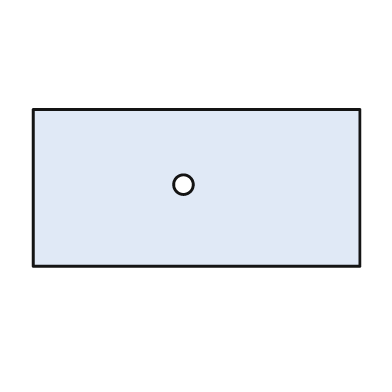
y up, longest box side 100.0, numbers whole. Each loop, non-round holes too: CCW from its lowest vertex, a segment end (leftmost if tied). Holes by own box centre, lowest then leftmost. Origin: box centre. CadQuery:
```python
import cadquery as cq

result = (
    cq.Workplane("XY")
    .moveTo(-50.0, -24.0)
    .lineTo(50.0, -24.0)
    .lineTo(50.0, 24.0)
    .lineTo(-50.0, 24.0)
    .close()
    .moveTo(-4.0, 1.0)
    .circle(3.0)
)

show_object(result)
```